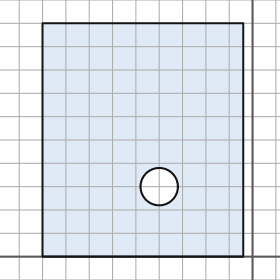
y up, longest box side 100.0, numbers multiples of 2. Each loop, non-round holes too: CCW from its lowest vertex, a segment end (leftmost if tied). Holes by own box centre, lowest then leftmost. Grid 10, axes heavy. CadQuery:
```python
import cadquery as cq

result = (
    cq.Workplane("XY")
    .moveTo(-90.0, 0.0)
    .lineTo(-4.0, 0.0)
    .lineTo(-4.0, 100.0)
    .lineTo(-90.0, 100.0)
    .close()
    .moveTo(-40.0, 30.0)
    .circle(8.0)
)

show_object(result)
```